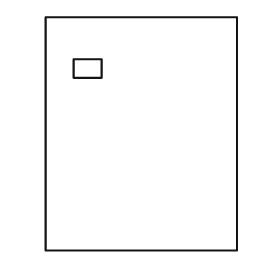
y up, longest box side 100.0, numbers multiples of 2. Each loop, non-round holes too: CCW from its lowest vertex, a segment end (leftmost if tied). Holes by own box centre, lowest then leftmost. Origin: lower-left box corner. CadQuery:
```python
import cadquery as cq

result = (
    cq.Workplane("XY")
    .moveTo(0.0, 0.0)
    .lineTo(82.0, 0.0)
    .lineTo(82.0, 100.0)
    .lineTo(0.0, 100.0)
    .close()
    .moveTo(12.0, 74.0)
    .lineTo(24.0, 74.0)
    .lineTo(24.0, 82.0)
    .lineTo(12.0, 82.0)
    .close()
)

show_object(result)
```